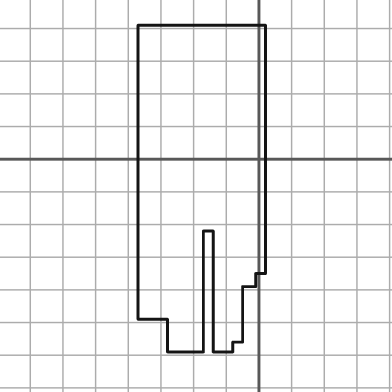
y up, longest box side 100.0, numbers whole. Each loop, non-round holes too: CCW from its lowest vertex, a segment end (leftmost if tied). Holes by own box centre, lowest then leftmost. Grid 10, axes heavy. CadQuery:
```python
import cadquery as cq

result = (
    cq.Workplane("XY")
    .moveTo(-28.0, -59.0)
    .lineTo(-17.0, -59.0)
    .lineTo(-17.0, -22.0)
    .lineTo(-14.0, -22.0)
    .lineTo(-14.0, -59.0)
    .lineTo(-8.0, -59.0)
    .lineTo(-8.0, -56.0)
    .lineTo(-5.0, -56.0)
    .lineTo(-5.0, -39.0)
    .lineTo(-1.0, -39.0)
    .lineTo(-1.0, -35.0)
    .lineTo(2.0, -35.0)
    .lineTo(2.0, 41.0)
    .lineTo(-37.0, 41.0)
    .lineTo(-37.0, -49.0)
    .lineTo(-28.0, -49.0)
    .close()
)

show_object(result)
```